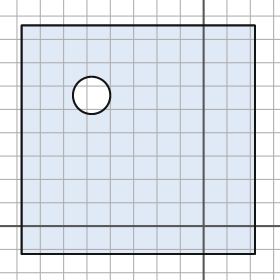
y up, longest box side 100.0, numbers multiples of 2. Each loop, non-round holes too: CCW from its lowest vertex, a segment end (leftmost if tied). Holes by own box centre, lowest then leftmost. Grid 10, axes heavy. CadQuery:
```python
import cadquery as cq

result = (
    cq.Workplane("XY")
    .moveTo(-78.0, -12.0)
    .lineTo(22.0, -12.0)
    .lineTo(22.0, 86.0)
    .lineTo(-78.0, 86.0)
    .close()
    .moveTo(-48.0, 56.0)
    .circle(8.0)
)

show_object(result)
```